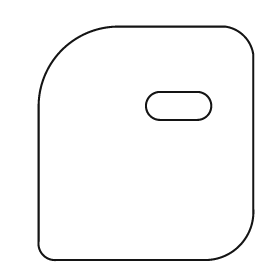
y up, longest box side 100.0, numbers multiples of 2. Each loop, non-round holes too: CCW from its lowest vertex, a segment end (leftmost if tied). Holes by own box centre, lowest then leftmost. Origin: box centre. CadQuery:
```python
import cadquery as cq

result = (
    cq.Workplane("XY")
    .moveTo(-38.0, -50.0)
    .lineTo(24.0, -50.0)
    .threePointArc((40.0, -44.0), (46.0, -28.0))
    .lineTo(46.0, 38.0)
    .threePointArc((42.0, 46.0), (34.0, 50.0))
    .lineTo(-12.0, 50.0)
    .threePointArc((-36.0, 40.0), (-46.0, 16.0))
    .lineTo(-46.0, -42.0)
    .threePointArc((-44.0, -48.0), (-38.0, -50.0))
    .close()
    .moveTo(6.0, 10.0)
    .lineTo(22.0, 10.0)
    .threePointArc((28.0, 16.0), (22.0, 22.0))
    .lineTo(6.0, 22.0)
    .threePointArc((0.0, 16.0), (6.0, 10.0))
    .close()
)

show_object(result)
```